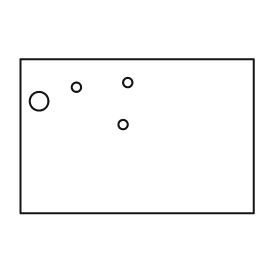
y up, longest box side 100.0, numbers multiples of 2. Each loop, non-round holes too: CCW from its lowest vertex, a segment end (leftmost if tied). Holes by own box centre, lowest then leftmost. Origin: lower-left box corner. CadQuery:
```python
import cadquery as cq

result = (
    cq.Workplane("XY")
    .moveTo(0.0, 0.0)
    .lineTo(100.0, 0.0)
    .lineTo(100.0, 66.0)
    .lineTo(0.0, 66.0)
    .close()
    .moveTo(44.0, 38.0)
    .circle(2.0)
    .moveTo(8.0, 48.0)
    .circle(4.0)
    .moveTo(24.0, 54.0)
    .circle(2.0)
    .moveTo(46.0, 56.0)
    .circle(2.0)
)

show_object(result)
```